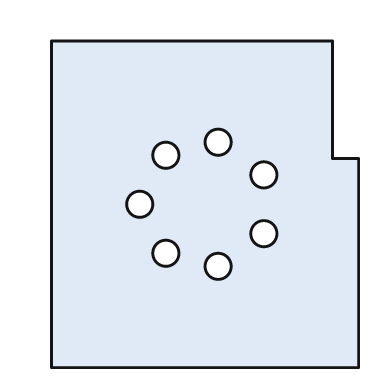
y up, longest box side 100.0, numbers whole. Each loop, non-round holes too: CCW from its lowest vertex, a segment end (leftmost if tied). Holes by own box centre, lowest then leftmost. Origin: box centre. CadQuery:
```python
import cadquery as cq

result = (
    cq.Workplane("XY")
    .moveTo(-47.0, -50.0)
    .lineTo(47.0, -50.0)
    .lineTo(47.0, 14.0)
    .lineTo(39.0, 14.0)
    .lineTo(39.0, 50.0)
    .lineTo(-47.0, 50.0)
    .close()
    .moveTo(4.0, -19.0)
    .circle(4.0)
    .moveTo(-12.0, -15.0)
    .circle(4.0)
    .moveTo(18.0, -9.0)
    .circle(4.0)
    .moveTo(-20.0, 0.0)
    .circle(4.0)
    .moveTo(18.0, 9.0)
    .circle(4.0)
    .moveTo(-12.0, 15.0)
    .circle(4.0)
    .moveTo(4.0, 19.0)
    .circle(4.0)
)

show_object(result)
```